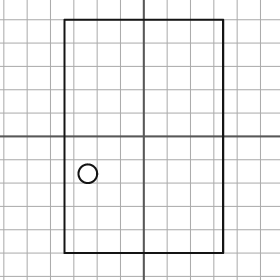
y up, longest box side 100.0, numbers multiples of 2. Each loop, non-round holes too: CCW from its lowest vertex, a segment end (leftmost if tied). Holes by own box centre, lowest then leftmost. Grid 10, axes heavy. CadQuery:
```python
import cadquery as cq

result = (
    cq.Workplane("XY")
    .moveTo(-34.0, -50.0)
    .lineTo(34.0, -50.0)
    .lineTo(34.0, 50.0)
    .lineTo(-34.0, 50.0)
    .close()
    .moveTo(-24.0, -16.0)
    .circle(4.0)
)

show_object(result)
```